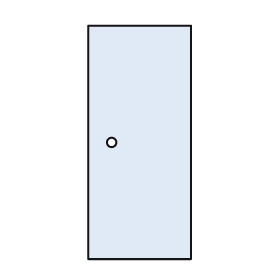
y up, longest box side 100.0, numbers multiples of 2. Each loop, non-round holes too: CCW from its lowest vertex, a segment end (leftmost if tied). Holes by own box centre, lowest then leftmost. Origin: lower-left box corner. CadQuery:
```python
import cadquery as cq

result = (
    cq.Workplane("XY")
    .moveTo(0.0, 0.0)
    .lineTo(44.0, 0.0)
    .lineTo(44.0, 100.0)
    .lineTo(0.0, 100.0)
    .close()
    .moveTo(10.0, 50.0)
    .circle(2.0)
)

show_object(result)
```